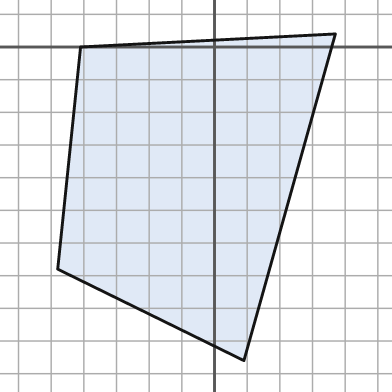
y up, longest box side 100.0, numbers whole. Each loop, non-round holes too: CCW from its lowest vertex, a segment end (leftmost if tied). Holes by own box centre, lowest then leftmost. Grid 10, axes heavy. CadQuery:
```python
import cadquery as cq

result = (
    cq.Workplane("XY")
    .moveTo(9.0, -96.0)
    .lineTo(37.0, 4.0)
    .lineTo(-41.0, 0.0)
    .lineTo(-48.0, -68.0)
    .close()
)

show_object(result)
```